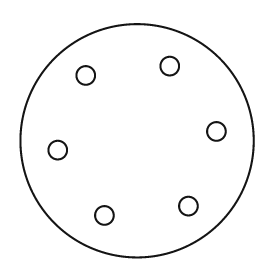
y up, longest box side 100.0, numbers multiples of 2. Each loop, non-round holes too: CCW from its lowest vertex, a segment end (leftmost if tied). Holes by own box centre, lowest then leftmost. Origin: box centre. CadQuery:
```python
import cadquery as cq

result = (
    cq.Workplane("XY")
    .moveTo(0.0, 0.0)
    .circle(50.0)
    .moveTo(-14.0, -32.0)
    .circle(4.0)
    .moveTo(22.0, -28.0)
    .circle(4.0)
    .moveTo(-34.0, -4.0)
    .circle(4.0)
    .moveTo(34.0, 4.0)
    .circle(4.0)
    .moveTo(-22.0, 28.0)
    .circle(4.0)
    .moveTo(14.0, 32.0)
    .circle(4.0)
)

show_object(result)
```